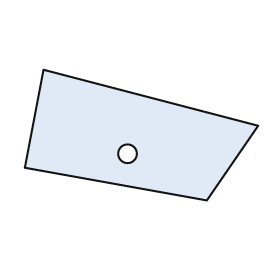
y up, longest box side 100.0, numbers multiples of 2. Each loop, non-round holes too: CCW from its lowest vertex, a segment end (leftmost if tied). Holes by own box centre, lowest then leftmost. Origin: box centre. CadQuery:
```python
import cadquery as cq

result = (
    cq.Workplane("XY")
    .moveTo(28.0, -28.0)
    .lineTo(50.0, 4.0)
    .lineTo(-42.0, 28.0)
    .lineTo(-50.0, -14.0)
    .close()
    .moveTo(-6.0, -8.0)
    .circle(4.0)
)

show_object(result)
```